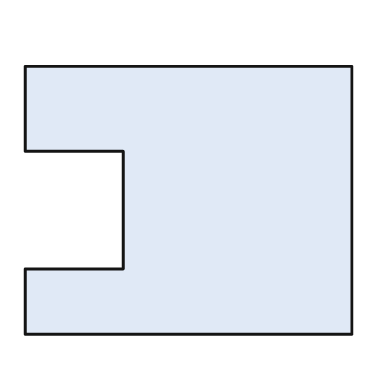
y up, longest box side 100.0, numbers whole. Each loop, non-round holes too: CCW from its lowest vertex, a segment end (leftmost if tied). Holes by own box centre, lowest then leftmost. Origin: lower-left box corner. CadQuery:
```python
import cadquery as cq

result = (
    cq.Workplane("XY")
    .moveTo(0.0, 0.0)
    .lineTo(100.0, 0.0)
    .lineTo(100.0, 82.0)
    .lineTo(0.0, 82.0)
    .lineTo(0.0, 56.0)
    .lineTo(30.0, 56.0)
    .lineTo(30.0, 20.0)
    .lineTo(0.0, 20.0)
    .close()
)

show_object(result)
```